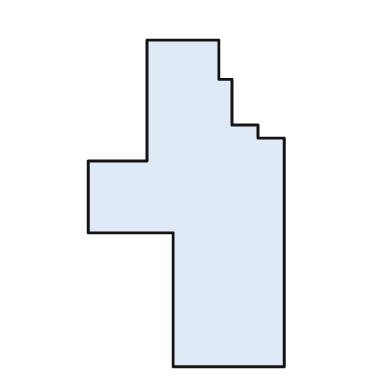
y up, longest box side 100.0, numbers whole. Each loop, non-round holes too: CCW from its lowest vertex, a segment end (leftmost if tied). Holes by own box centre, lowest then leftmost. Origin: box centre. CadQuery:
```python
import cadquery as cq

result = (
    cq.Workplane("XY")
    .moveTo(-4.0, -50.0)
    .lineTo(30.0, -50.0)
    .lineTo(30.0, 20.0)
    .lineTo(22.0, 20.0)
    .lineTo(22.0, 24.0)
    .lineTo(14.0, 24.0)
    .lineTo(14.0, 38.0)
    .lineTo(10.0, 38.0)
    .lineTo(10.0, 50.0)
    .lineTo(-12.0, 50.0)
    .lineTo(-12.0, 13.0)
    .lineTo(-30.0, 13.0)
    .lineTo(-30.0, -9.0)
    .lineTo(-4.0, -9.0)
    .close()
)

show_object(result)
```